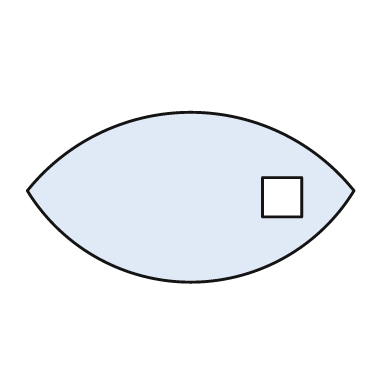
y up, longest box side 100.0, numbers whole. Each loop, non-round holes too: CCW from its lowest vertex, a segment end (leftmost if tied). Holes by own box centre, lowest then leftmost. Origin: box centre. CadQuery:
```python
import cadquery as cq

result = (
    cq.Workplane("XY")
    .moveTo(-50.0, 2.0)
    .threePointArc((0.0, -26.0), (50.0, 2.0))
    .threePointArc((0.0, 26.0), (-50.0, 2.0))
    .close()
    .moveTo(22.0, -6.0)
    .lineTo(34.0, -6.0)
    .lineTo(34.0, 6.0)
    .lineTo(22.0, 6.0)
    .close()
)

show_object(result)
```